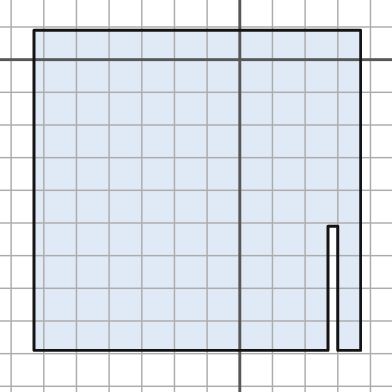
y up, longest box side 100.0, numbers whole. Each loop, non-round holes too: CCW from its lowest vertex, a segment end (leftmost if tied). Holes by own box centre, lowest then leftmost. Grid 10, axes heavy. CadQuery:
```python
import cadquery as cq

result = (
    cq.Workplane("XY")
    .moveTo(-63.0, -89.0)
    .lineTo(27.0, -89.0)
    .lineTo(27.0, -51.0)
    .lineTo(30.0, -51.0)
    .lineTo(30.0, -89.0)
    .lineTo(37.0, -89.0)
    .lineTo(37.0, 9.0)
    .lineTo(-63.0, 9.0)
    .close()
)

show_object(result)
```